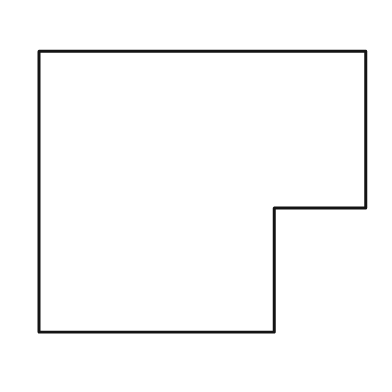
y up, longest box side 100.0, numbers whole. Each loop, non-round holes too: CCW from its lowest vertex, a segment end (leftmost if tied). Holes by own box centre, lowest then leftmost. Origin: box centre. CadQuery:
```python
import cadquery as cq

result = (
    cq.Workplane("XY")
    .moveTo(-50.0, -43.0)
    .lineTo(22.0, -43.0)
    .lineTo(22.0, -5.0)
    .lineTo(50.0, -5.0)
    .lineTo(50.0, 43.0)
    .lineTo(-50.0, 43.0)
    .close()
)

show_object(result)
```